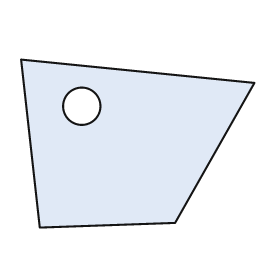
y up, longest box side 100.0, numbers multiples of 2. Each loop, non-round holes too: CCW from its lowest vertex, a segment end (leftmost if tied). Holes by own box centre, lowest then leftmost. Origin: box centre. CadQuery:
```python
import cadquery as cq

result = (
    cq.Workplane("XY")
    .moveTo(-42.0, -36.0)
    .lineTo(16.0, -34.0)
    .lineTo(50.0, 26.0)
    .lineTo(-50.0, 36.0)
    .close()
    .moveTo(-24.0, 16.0)
    .circle(8.0)
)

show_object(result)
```